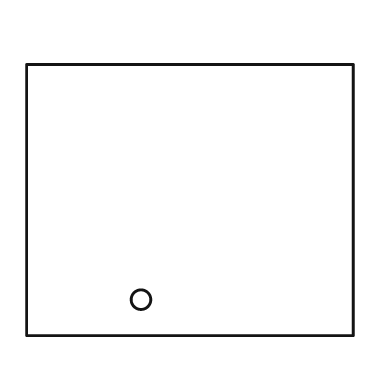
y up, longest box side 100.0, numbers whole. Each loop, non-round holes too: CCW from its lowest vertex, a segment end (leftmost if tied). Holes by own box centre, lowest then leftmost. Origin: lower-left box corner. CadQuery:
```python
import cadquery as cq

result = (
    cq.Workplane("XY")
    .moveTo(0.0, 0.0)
    .lineTo(100.0, 0.0)
    .lineTo(100.0, 83.0)
    .lineTo(0.0, 83.0)
    .close()
    .moveTo(35.0, 11.0)
    .circle(3.0)
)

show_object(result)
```